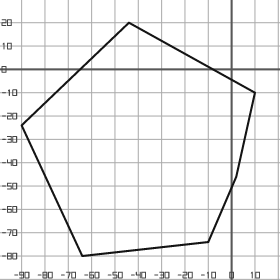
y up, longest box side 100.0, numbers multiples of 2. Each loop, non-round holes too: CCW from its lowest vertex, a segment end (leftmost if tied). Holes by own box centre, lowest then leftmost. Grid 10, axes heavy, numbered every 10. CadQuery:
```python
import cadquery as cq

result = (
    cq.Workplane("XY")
    .moveTo(-64.0, -80.0)
    .lineTo(-10.0, -74.0)
    .lineTo(2.0, -46.0)
    .lineTo(10.0, -10.0)
    .lineTo(-44.0, 20.0)
    .lineTo(-90.0, -24.0)
    .close()
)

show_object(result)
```